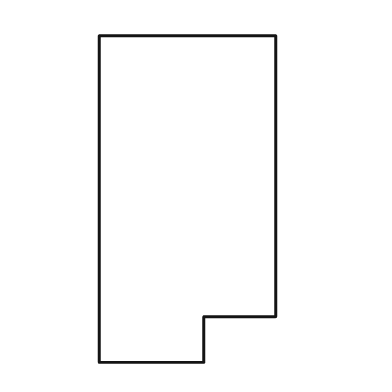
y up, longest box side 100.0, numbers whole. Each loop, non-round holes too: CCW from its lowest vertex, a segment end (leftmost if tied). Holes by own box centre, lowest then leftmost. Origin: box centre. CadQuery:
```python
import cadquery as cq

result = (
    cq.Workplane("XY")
    .moveTo(-27.0, -50.0)
    .lineTo(5.0, -50.0)
    .lineTo(5.0, -36.0)
    .lineTo(27.0, -36.0)
    .lineTo(27.0, 50.0)
    .lineTo(-27.0, 50.0)
    .close()
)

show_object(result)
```